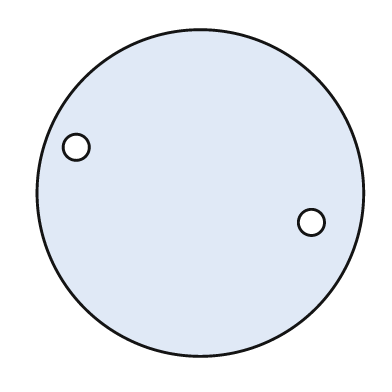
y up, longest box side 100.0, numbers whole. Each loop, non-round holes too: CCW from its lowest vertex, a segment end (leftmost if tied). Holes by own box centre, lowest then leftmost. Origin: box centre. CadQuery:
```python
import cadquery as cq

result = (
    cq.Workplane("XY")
    .moveTo(0.0, 0.0)
    .circle(50.0)
    .moveTo(34.0, -9.0)
    .circle(4.0)
    .moveTo(-38.0, 14.0)
    .circle(4.0)
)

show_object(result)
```